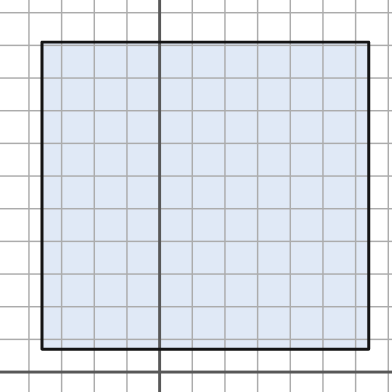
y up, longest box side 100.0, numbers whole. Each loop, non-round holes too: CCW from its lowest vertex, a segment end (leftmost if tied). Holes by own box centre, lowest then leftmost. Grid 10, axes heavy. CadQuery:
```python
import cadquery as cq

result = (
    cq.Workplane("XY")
    .moveTo(-36.0, 7.0)
    .lineTo(64.0, 7.0)
    .lineTo(64.0, 101.0)
    .lineTo(-36.0, 101.0)
    .close()
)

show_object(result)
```